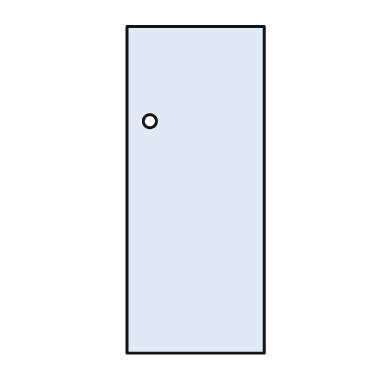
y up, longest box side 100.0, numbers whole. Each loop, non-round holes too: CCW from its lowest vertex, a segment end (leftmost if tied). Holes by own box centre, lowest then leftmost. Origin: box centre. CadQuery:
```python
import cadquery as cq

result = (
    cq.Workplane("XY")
    .moveTo(-21.0, -50.0)
    .lineTo(21.0, -50.0)
    .lineTo(21.0, 50.0)
    .lineTo(-21.0, 50.0)
    .close()
    .moveTo(-14.0, 21.0)
    .circle(2.0)
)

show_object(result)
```